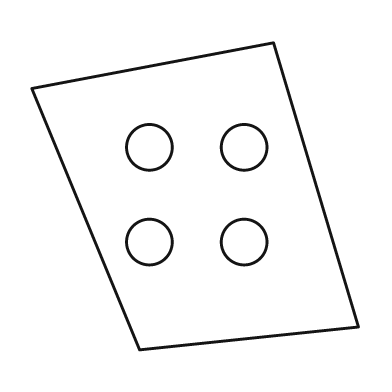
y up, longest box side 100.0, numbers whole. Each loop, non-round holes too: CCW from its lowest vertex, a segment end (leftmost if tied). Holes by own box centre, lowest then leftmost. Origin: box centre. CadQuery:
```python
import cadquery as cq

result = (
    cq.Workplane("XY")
    .moveTo(-17.0, -47.0)
    .lineTo(50.0, -40.0)
    .lineTo(24.0, 47.0)
    .lineTo(-50.0, 33.0)
    .close()
    .moveTo(-14.0, -14.0)
    .circle(7.0)
    .moveTo(15.0, -14.0)
    .circle(7.0)
    .moveTo(-14.0, 15.0)
    .circle(7.0)
    .moveTo(15.0, 15.0)
    .circle(7.0)
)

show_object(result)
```